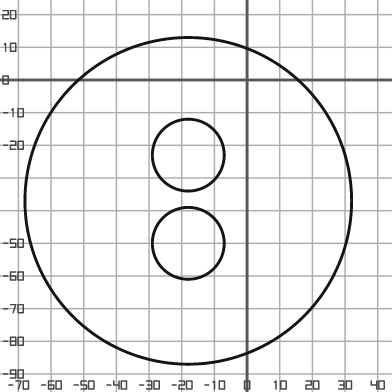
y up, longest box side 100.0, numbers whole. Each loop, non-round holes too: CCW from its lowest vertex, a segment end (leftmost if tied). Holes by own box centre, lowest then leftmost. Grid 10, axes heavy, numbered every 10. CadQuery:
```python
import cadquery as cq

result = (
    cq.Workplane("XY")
    .moveTo(-18.0, -37.0)
    .circle(50.0)
    .moveTo(-18.0, -50.0)
    .circle(11.0)
    .moveTo(-18.0, -23.0)
    .circle(11.0)
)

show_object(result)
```